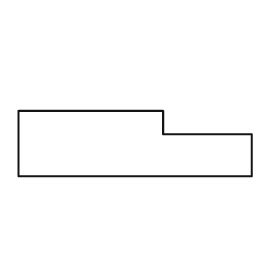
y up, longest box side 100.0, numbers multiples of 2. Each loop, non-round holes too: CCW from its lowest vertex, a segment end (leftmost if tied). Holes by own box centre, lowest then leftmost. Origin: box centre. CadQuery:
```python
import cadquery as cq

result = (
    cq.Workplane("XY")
    .moveTo(-50.0, -14.0)
    .lineTo(50.0, -14.0)
    .lineTo(50.0, 4.0)
    .lineTo(12.0, 4.0)
    .lineTo(12.0, 14.0)
    .lineTo(-50.0, 14.0)
    .close()
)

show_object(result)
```